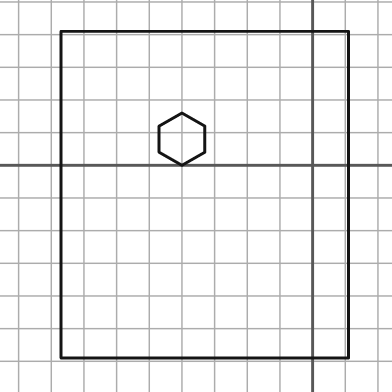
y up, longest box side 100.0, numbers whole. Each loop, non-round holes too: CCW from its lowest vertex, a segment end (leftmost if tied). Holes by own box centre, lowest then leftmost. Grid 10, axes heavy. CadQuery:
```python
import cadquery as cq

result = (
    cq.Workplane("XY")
    .moveTo(-77.0, -59.0)
    .lineTo(11.0, -59.0)
    .lineTo(11.0, 41.0)
    .lineTo(-77.0, 41.0)
    .close()
    .moveTo(-40.0, 0.0)
    .lineTo(-33.0, 4.0)
    .lineTo(-33.0, 12.0)
    .lineTo(-40.0, 16.0)
    .lineTo(-47.0, 12.0)
    .lineTo(-47.0, 4.0)
    .close()
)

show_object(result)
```